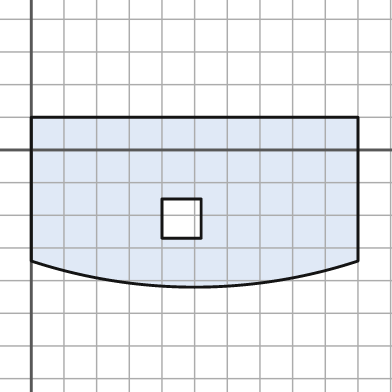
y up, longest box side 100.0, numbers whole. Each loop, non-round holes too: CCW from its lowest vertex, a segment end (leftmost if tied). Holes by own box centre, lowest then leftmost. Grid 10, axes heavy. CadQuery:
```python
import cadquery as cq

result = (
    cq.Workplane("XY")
    .moveTo(0.0, -34.0)
    .threePointArc((50.0, -42.0), (100.0, -34.0))
    .lineTo(100.0, 10.0)
    .lineTo(0.0, 10.0)
    .close()
    .moveTo(40.0, -27.0)
    .lineTo(52.0, -27.0)
    .lineTo(52.0, -15.0)
    .lineTo(40.0, -15.0)
    .close()
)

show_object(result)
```